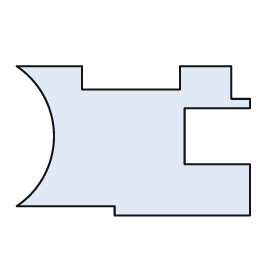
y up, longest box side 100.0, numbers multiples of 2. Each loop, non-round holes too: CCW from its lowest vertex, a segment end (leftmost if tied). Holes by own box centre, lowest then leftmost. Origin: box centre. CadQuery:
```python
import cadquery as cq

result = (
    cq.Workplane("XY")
    .moveTo(-8.0, -32.0)
    .lineTo(50.0, -32.0)
    .lineTo(50.0, -10.0)
    .lineTo(22.0, -10.0)
    .lineTo(22.0, 14.0)
    .lineTo(50.0, 14.0)
    .lineTo(50.0, 18.0)
    .lineTo(42.0, 18.0)
    .lineTo(42.0, 32.0)
    .lineTo(20.0, 32.0)
    .lineTo(20.0, 22.0)
    .lineTo(-22.0, 22.0)
    .lineTo(-22.0, 32.0)
    .lineTo(-50.0, 32.0)
    .threePointArc((-34.0, 2.0), (-50.0, -28.0))
    .lineTo(-8.0, -28.0)
    .close()
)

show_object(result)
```